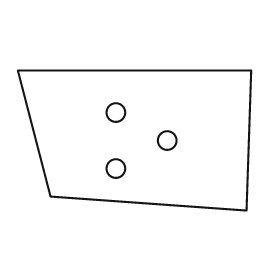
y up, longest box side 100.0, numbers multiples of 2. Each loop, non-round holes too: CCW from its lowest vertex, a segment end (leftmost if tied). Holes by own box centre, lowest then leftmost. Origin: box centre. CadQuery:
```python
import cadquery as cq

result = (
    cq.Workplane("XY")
    .moveTo(48.0, -30.0)
    .lineTo(50.0, 30.0)
    .lineTo(-50.0, 30.0)
    .lineTo(-36.0, -24.0)
    .close()
    .moveTo(-8.0, -12.0)
    .circle(4.0)
    .moveTo(14.0, 0.0)
    .circle(4.0)
    .moveTo(-8.0, 12.0)
    .circle(4.0)
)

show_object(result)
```